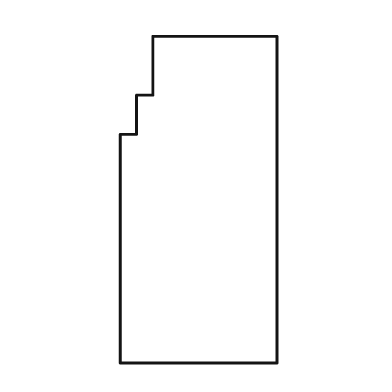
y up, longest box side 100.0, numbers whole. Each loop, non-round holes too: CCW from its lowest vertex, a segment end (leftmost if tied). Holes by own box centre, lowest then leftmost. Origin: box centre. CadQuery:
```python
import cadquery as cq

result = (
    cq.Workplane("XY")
    .moveTo(-24.0, -50.0)
    .lineTo(24.0, -50.0)
    .lineTo(24.0, 50.0)
    .lineTo(-14.0, 50.0)
    .lineTo(-14.0, 32.0)
    .lineTo(-19.0, 32.0)
    .lineTo(-19.0, 20.0)
    .lineTo(-24.0, 20.0)
    .close()
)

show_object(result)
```